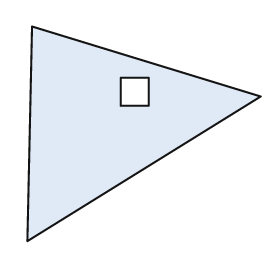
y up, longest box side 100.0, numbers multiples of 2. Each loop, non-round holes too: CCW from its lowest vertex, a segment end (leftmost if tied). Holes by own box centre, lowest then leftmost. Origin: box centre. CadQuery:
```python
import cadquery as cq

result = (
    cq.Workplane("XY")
    .moveTo(-50.0, -46.0)
    .lineTo(50.0, 16.0)
    .lineTo(-48.0, 46.0)
    .close()
    .moveTo(-10.0, 12.0)
    .lineTo(2.0, 12.0)
    .lineTo(2.0, 24.0)
    .lineTo(-10.0, 24.0)
    .close()
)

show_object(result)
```